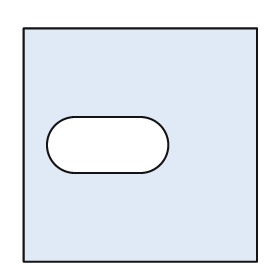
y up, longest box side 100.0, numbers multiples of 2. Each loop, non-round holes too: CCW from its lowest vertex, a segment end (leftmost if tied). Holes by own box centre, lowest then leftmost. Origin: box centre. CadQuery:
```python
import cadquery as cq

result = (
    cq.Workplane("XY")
    .moveTo(-50.0, -50.0)
    .lineTo(50.0, -50.0)
    .lineTo(50.0, 50.0)
    .lineTo(-50.0, 50.0)
    .close()
    .moveTo(-28.0, -12.0)
    .lineTo(0.0, -12.0)
    .threePointArc((12.0, 0.0), (0.0, 12.0))
    .lineTo(-28.0, 12.0)
    .threePointArc((-40.0, 0.0), (-28.0, -12.0))
    .close()
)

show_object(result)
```